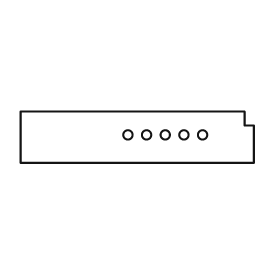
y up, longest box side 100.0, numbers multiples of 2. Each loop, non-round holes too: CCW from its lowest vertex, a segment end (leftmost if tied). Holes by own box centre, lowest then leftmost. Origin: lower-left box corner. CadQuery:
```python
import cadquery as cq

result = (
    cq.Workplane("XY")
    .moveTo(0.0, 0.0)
    .lineTo(100.0, 0.0)
    .lineTo(100.0, 16.0)
    .lineTo(96.0, 16.0)
    .lineTo(96.0, 22.0)
    .lineTo(0.0, 22.0)
    .close()
    .moveTo(46.0, 12.0)
    .circle(2.0)
    .moveTo(54.0, 12.0)
    .circle(2.0)
    .moveTo(62.0, 12.0)
    .circle(2.0)
    .moveTo(70.0, 12.0)
    .circle(2.0)
    .moveTo(78.0, 12.0)
    .circle(2.0)
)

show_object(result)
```